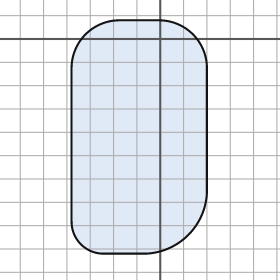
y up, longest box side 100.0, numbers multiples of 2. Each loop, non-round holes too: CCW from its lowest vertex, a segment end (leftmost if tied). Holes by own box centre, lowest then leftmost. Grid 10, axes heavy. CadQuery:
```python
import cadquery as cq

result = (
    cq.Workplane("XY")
    .moveTo(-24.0, -92.0)
    .lineTo(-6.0, -92.0)
    .threePointArc((12.0, -84.0), (20.0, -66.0))
    .lineTo(20.0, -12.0)
    .threePointArc((14.0, 2.0), (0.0, 8.0))
    .lineTo(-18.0, 8.0)
    .threePointArc((-32.0, 2.0), (-38.0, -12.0))
    .lineTo(-38.0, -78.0)
    .threePointArc((-34.0, -88.0), (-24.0, -92.0))
    .close()
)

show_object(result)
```